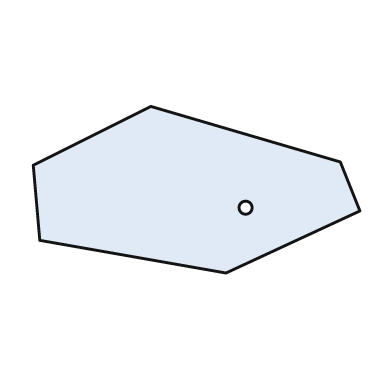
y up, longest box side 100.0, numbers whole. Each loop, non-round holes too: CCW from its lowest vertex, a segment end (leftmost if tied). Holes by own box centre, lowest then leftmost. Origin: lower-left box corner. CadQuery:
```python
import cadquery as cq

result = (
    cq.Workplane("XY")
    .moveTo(59.0, 0.0)
    .lineTo(100.0, 19.0)
    .lineTo(94.0, 34.0)
    .lineTo(36.0, 51.0)
    .lineTo(0.0, 33.0)
    .lineTo(2.0, 10.0)
    .close()
    .moveTo(65.0, 20.0)
    .circle(2.0)
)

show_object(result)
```